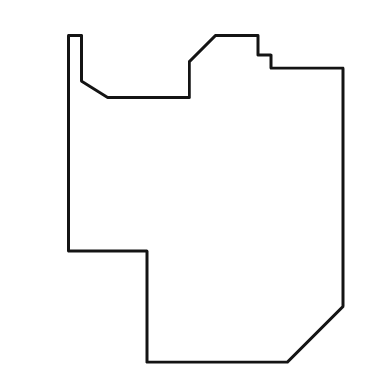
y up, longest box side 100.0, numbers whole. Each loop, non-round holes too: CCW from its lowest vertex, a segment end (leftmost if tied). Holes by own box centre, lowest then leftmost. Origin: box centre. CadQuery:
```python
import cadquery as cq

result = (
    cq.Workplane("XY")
    .moveTo(-18.0, -50.0)
    .lineTo(25.0, -50.0)
    .lineTo(42.0, -33.0)
    .lineTo(42.0, 40.0)
    .lineTo(20.0, 40.0)
    .lineTo(20.0, 44.0)
    .lineTo(16.0, 44.0)
    .lineTo(16.0, 50.0)
    .lineTo(3.0, 50.0)
    .lineTo(-5.0, 42.0)
    .lineTo(-5.0, 31.0)
    .lineTo(-30.0, 31.0)
    .lineTo(-38.0, 36.0)
    .lineTo(-38.0, 50.0)
    .lineTo(-42.0, 50.0)
    .lineTo(-42.0, -16.0)
    .lineTo(-18.0, -16.0)
    .close()
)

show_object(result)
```